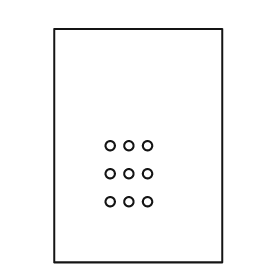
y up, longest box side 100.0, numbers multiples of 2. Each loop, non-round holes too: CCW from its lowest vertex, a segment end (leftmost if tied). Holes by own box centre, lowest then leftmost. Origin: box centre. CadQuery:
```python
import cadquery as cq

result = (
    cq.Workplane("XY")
    .moveTo(-36.0, -50.0)
    .lineTo(36.0, -50.0)
    .lineTo(36.0, 50.0)
    .lineTo(-36.0, 50.0)
    .close()
    .moveTo(-12.0, -24.0)
    .circle(2.0)
    .moveTo(-4.0, -24.0)
    .circle(2.0)
    .moveTo(4.0, -24.0)
    .circle(2.0)
    .moveTo(-12.0, -12.0)
    .circle(2.0)
    .moveTo(-4.0, -12.0)
    .circle(2.0)
    .moveTo(4.0, -12.0)
    .circle(2.0)
    .moveTo(-12.0, 0.0)
    .circle(2.0)
    .moveTo(-4.0, 0.0)
    .circle(2.0)
    .moveTo(4.0, 0.0)
    .circle(2.0)
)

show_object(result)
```